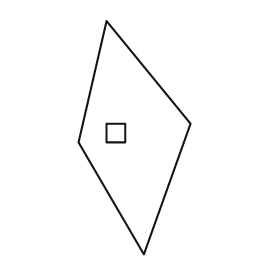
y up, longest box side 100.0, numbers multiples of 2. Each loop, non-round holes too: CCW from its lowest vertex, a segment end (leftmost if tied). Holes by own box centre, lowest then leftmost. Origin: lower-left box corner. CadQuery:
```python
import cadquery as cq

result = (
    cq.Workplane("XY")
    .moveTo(28.0, 0.0)
    .lineTo(48.0, 56.0)
    .lineTo(12.0, 100.0)
    .lineTo(0.0, 48.0)
    .close()
    .moveTo(12.0, 48.0)
    .lineTo(20.0, 48.0)
    .lineTo(20.0, 56.0)
    .lineTo(12.0, 56.0)
    .close()
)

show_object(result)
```